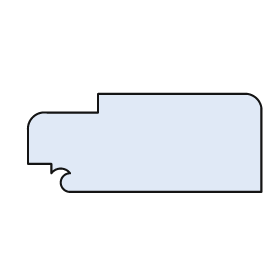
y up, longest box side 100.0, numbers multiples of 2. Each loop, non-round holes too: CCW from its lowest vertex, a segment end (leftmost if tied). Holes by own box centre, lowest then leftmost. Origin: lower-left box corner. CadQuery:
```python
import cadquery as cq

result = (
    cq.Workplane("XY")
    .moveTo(18.0, 0.0)
    .lineTo(100.0, 0.0)
    .lineTo(100.0, 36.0)
    .threePointArc((98.0, 40.0), (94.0, 42.0))
    .lineTo(30.0, 42.0)
    .lineTo(30.0, 34.0)
    .lineTo(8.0, 34.0)
    .threePointArc((2.0, 32.0), (0.0, 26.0))
    .lineTo(0.0, 12.0)
    .lineTo(10.0, 12.0)
    .lineTo(10.0, 8.0)
    .threePointArc((14.0, 10.0), (18.0, 8.0))
    .threePointArc((14.0, 4.0), (18.0, 0.0))
    .close()
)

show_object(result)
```